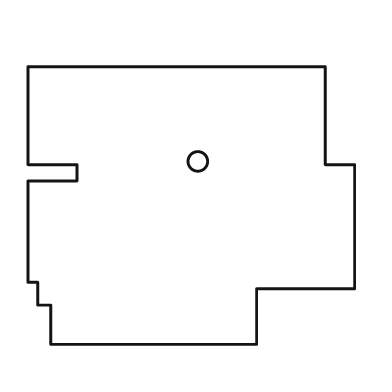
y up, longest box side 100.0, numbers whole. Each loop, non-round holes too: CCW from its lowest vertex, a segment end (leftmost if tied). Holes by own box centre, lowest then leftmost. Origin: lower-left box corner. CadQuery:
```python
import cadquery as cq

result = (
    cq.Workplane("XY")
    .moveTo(7.0, 0.0)
    .lineTo(70.0, 0.0)
    .lineTo(70.0, 17.0)
    .lineTo(100.0, 17.0)
    .lineTo(100.0, 55.0)
    .lineTo(91.0, 55.0)
    .lineTo(91.0, 85.0)
    .lineTo(0.0, 85.0)
    .lineTo(0.0, 55.0)
    .lineTo(15.0, 55.0)
    .lineTo(15.0, 50.0)
    .lineTo(0.0, 50.0)
    .lineTo(0.0, 19.0)
    .lineTo(3.0, 19.0)
    .lineTo(3.0, 12.0)
    .lineTo(7.0, 12.0)
    .close()
    .moveTo(52.0, 56.0)
    .circle(3.0)
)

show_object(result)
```